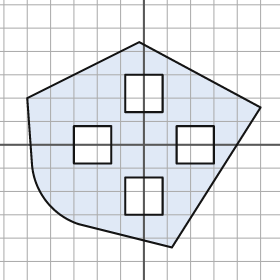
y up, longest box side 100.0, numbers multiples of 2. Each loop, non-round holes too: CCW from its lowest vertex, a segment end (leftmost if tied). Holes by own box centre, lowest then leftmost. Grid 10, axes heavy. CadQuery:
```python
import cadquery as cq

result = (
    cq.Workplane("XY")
    .moveTo(12.0, -44.0)
    .lineTo(50.0, 16.0)
    .lineTo(-2.0, 44.0)
    .lineTo(-50.0, 20.0)
    .lineTo(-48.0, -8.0)
    .threePointArc((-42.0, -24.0), (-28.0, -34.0))
    .close()
    .moveTo(-8.0, -30.0)
    .lineTo(8.0, -30.0)
    .lineTo(8.0, -14.0)
    .lineTo(-8.0, -14.0)
    .close()
    .moveTo(-30.0, -8.0)
    .lineTo(-14.0, -8.0)
    .lineTo(-14.0, 8.0)
    .lineTo(-30.0, 8.0)
    .close()
    .moveTo(14.0, -8.0)
    .lineTo(30.0, -8.0)
    .lineTo(30.0, 8.0)
    .lineTo(14.0, 8.0)
    .close()
    .moveTo(-8.0, 14.0)
    .lineTo(8.0, 14.0)
    .lineTo(8.0, 30.0)
    .lineTo(-8.0, 30.0)
    .close()
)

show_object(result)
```